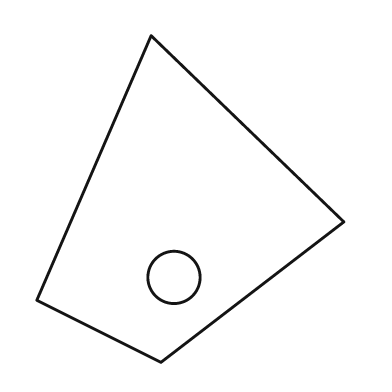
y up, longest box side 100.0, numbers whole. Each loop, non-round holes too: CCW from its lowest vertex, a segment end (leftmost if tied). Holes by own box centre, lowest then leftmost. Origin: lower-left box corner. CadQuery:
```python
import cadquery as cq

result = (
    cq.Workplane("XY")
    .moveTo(38.0, 0.0)
    .lineTo(94.0, 43.0)
    .lineTo(35.0, 100.0)
    .lineTo(0.0, 19.0)
    .close()
    .moveTo(42.0, 26.0)
    .circle(8.0)
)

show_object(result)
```